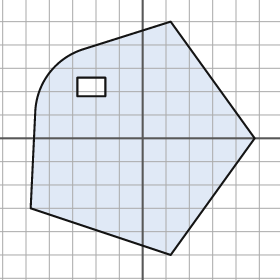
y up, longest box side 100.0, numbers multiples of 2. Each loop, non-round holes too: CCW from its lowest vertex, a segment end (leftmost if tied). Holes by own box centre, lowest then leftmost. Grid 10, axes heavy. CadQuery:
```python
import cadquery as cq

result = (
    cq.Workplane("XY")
    .moveTo(12.0, -50.0)
    .lineTo(48.0, 0.0)
    .lineTo(12.0, 50.0)
    .lineTo(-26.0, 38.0)
    .threePointArc((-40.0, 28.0), (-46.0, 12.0))
    .lineTo(-48.0, -30.0)
    .close()
    .moveTo(-28.0, 18.0)
    .lineTo(-16.0, 18.0)
    .lineTo(-16.0, 26.0)
    .lineTo(-28.0, 26.0)
    .close()
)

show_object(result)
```